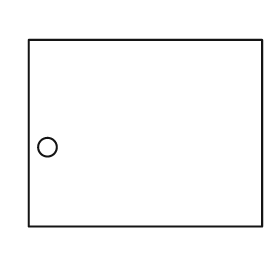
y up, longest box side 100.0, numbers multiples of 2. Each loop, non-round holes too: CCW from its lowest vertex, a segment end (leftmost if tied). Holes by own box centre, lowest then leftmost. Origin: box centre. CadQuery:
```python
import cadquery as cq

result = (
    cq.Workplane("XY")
    .moveTo(-50.0, -40.0)
    .lineTo(50.0, -40.0)
    .lineTo(50.0, 40.0)
    .lineTo(-50.0, 40.0)
    .close()
    .moveTo(-42.0, -6.0)
    .circle(4.0)
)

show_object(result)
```